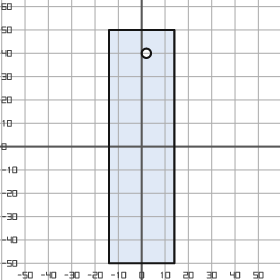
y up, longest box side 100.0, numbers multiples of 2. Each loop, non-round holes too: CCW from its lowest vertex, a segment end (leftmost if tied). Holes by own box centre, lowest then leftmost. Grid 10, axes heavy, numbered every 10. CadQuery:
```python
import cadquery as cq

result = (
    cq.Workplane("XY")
    .moveTo(-14.0, -50.0)
    .lineTo(14.0, -50.0)
    .lineTo(14.0, 50.0)
    .lineTo(-14.0, 50.0)
    .close()
    .moveTo(2.0, 40.0)
    .circle(2.0)
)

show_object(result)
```